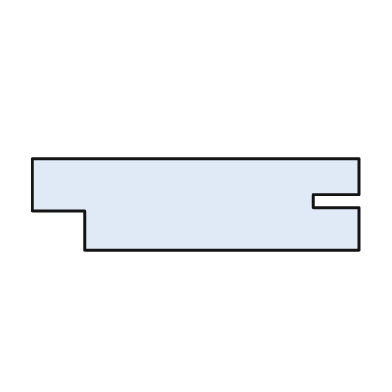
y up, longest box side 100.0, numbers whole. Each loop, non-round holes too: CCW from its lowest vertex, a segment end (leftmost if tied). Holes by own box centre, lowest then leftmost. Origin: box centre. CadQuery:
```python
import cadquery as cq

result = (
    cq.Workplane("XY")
    .moveTo(-34.0, -14.0)
    .lineTo(50.0, -14.0)
    .lineTo(50.0, -1.0)
    .lineTo(36.0, -1.0)
    .lineTo(36.0, 3.0)
    .lineTo(50.0, 3.0)
    .lineTo(50.0, 14.0)
    .lineTo(-50.0, 14.0)
    .lineTo(-50.0, -2.0)
    .lineTo(-34.0, -2.0)
    .close()
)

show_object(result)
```